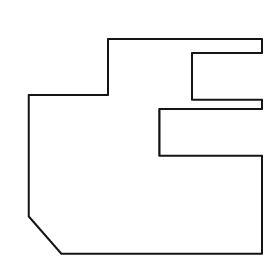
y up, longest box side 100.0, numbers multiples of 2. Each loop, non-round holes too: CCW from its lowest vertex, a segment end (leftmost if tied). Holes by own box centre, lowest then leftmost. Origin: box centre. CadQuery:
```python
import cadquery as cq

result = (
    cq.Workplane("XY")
    .moveTo(-36.0, -46.0)
    .lineTo(50.0, -46.0)
    .lineTo(50.0, -4.0)
    .lineTo(6.0, -4.0)
    .lineTo(6.0, 16.0)
    .lineTo(50.0, 16.0)
    .lineTo(50.0, 20.0)
    .lineTo(20.0, 20.0)
    .lineTo(20.0, 40.0)
    .lineTo(50.0, 40.0)
    .lineTo(50.0, 46.0)
    .lineTo(-16.0, 46.0)
    .lineTo(-16.0, 22.0)
    .lineTo(-50.0, 22.0)
    .lineTo(-50.0, -30.0)
    .close()
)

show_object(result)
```